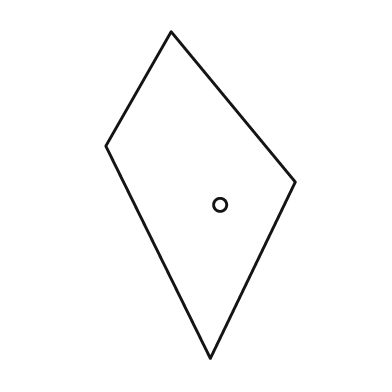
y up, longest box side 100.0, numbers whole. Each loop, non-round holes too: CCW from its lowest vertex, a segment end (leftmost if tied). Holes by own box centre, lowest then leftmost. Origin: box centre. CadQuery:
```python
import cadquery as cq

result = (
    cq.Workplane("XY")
    .moveTo(3.0, -50.0)
    .lineTo(29.0, 4.0)
    .lineTo(-9.0, 50.0)
    .lineTo(-29.0, 15.0)
    .close()
    .moveTo(6.0, -3.0)
    .circle(2.0)
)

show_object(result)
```